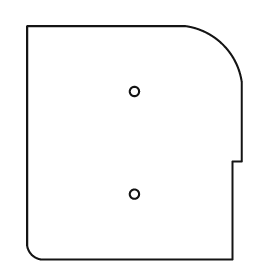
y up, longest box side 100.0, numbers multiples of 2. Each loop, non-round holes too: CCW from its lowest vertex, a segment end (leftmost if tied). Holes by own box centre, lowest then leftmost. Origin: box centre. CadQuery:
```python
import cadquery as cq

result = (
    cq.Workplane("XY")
    .moveTo(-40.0, -50.0)
    .lineTo(42.0, -50.0)
    .lineTo(42.0, -8.0)
    .lineTo(46.0, -8.0)
    .lineTo(46.0, 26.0)
    .threePointArc((38.0, 42.0), (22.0, 50.0))
    .lineTo(-46.0, 50.0)
    .lineTo(-46.0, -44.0)
    .threePointArc((-44.0, -48.0), (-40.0, -50.0))
    .close()
    .moveTo(0.0, -22.0)
    .circle(2.0)
    .moveTo(0.0, 22.0)
    .circle(2.0)
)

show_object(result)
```